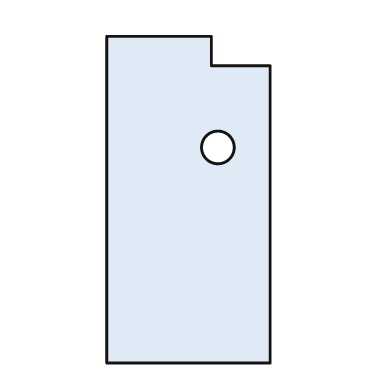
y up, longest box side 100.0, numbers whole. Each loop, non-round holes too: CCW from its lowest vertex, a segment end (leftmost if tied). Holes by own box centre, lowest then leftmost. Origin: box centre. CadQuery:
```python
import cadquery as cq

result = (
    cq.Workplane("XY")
    .moveTo(-25.0, -50.0)
    .lineTo(25.0, -50.0)
    .lineTo(25.0, 41.0)
    .lineTo(7.0, 41.0)
    .lineTo(7.0, 50.0)
    .lineTo(-25.0, 50.0)
    .close()
    .moveTo(9.0, 16.0)
    .circle(5.0)
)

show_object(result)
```